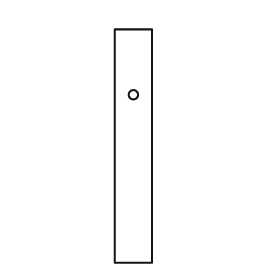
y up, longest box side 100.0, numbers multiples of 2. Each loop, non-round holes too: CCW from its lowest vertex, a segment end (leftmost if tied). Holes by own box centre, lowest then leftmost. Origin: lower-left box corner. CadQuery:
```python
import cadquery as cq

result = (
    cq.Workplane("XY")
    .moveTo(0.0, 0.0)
    .lineTo(16.0, 0.0)
    .lineTo(16.0, 100.0)
    .lineTo(0.0, 100.0)
    .close()
    .moveTo(8.0, 72.0)
    .circle(2.0)
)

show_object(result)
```